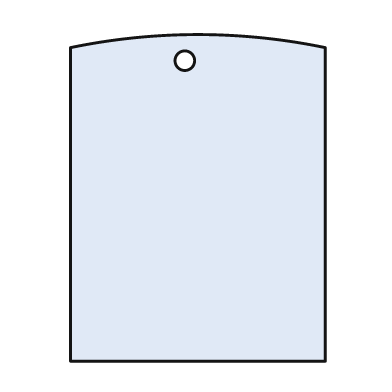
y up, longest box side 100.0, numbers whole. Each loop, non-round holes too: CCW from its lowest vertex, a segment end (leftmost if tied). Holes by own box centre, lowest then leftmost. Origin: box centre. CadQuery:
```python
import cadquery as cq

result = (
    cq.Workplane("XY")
    .moveTo(-39.0, -50.0)
    .lineTo(39.0, -50.0)
    .lineTo(39.0, 46.0)
    .threePointArc((0.0, 50.0), (-39.0, 46.0))
    .close()
    .moveTo(-4.0, 42.0)
    .circle(3.0)
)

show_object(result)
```